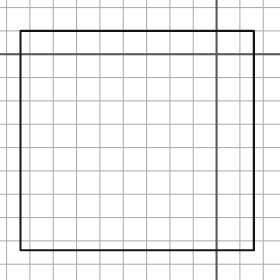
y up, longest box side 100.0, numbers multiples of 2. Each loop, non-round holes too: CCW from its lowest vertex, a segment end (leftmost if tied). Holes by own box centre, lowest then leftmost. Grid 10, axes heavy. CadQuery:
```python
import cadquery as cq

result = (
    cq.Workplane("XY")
    .moveTo(-84.0, -84.0)
    .lineTo(16.0, -84.0)
    .lineTo(16.0, 10.0)
    .lineTo(-84.0, 10.0)
    .close()
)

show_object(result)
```